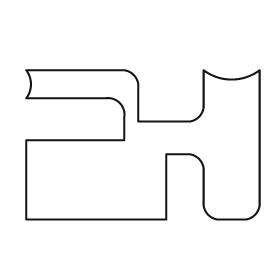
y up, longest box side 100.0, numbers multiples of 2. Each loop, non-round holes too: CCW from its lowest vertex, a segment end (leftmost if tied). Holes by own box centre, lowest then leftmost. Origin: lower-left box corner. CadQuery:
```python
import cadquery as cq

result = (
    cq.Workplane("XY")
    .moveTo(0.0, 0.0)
    .lineTo(60.0, 0.0)
    .lineTo(60.0, 28.0)
    .lineTo(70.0, 28.0)
    .threePointArc((74.0, 26.0), (76.0, 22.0))
    .lineTo(76.0, 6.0)
    .threePointArc((78.0, 2.0), (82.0, 0.0))
    .lineTo(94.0, 0.0)
    .threePointArc((98.0, 2.0), (100.0, 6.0))
    .lineTo(100.0, 64.0)
    .threePointArc((88.0, 60.0), (76.0, 64.0))
    .lineTo(76.0, 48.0)
    .threePointArc((74.0, 44.0), (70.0, 42.0))
    .lineTo(48.0, 42.0)
    .lineTo(48.0, 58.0)
    .threePointArc((46.0, 62.0), (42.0, 64.0))
    .lineTo(0.0, 64.0)
    .threePointArc((2.0, 58.0), (0.0, 52.0))
    .lineTo(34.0, 52.0)
    .threePointArc((40.0, 50.0), (42.0, 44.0))
    .lineTo(42.0, 34.0)
    .lineTo(0.0, 34.0)
    .close()
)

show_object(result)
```